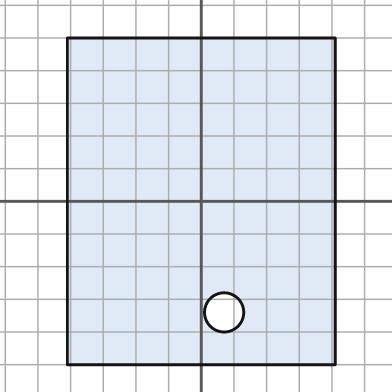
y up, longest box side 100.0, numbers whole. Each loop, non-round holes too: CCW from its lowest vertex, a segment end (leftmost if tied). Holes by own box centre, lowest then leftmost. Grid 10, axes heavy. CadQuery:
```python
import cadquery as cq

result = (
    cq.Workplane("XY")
    .moveTo(-41.0, -50.0)
    .lineTo(41.0, -50.0)
    .lineTo(41.0, 50.0)
    .lineTo(-41.0, 50.0)
    .close()
    .moveTo(7.0, -34.0)
    .circle(6.0)
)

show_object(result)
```